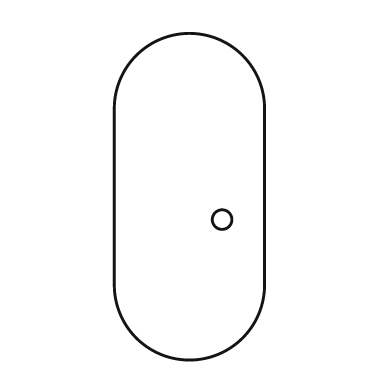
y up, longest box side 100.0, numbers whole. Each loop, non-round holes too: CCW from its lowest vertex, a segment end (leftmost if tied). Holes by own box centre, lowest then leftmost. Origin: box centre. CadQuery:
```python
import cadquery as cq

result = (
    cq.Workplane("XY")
    .moveTo(-23.0, -27.0)
    .threePointArc((0.0, -50.0), (23.0, -27.0))
    .lineTo(23.0, 27.0)
    .threePointArc((0.0, 50.0), (-23.0, 27.0))
    .close()
    .moveTo(10.0, -7.0)
    .circle(3.0)
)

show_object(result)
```